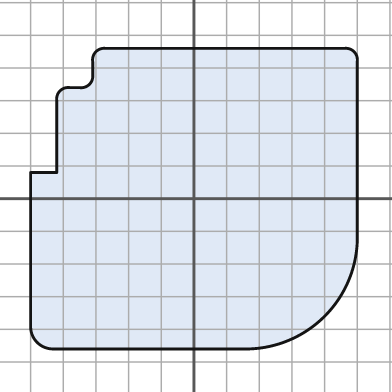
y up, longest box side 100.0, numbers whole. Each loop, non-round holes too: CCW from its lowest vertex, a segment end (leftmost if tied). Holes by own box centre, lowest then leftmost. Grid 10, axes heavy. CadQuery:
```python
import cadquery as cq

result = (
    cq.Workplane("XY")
    .moveTo(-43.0, -46.0)
    .lineTo(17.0, -46.0)
    .threePointArc((40.0, -36.0), (50.0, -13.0))
    .lineTo(50.0, 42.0)
    .threePointArc((49.0, 45.0), (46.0, 46.0))
    .lineTo(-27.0, 46.0)
    .threePointArc((-30.0, 45.0), (-31.0, 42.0))
    .lineTo(-31.0, 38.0)
    .threePointArc((-32.0, 35.0), (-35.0, 34.0))
    .lineTo(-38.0, 34.0)
    .threePointArc((-41.0, 33.0), (-42.0, 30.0))
    .lineTo(-42.0, 8.0)
    .lineTo(-50.0, 8.0)
    .lineTo(-50.0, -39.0)
    .threePointArc((-48.0, -44.0), (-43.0, -46.0))
    .close()
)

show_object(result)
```